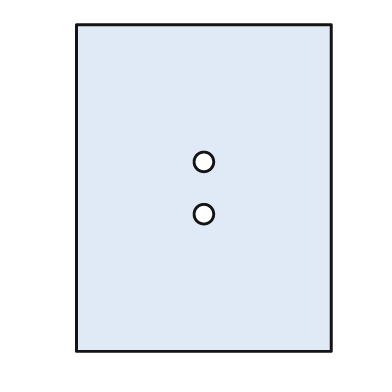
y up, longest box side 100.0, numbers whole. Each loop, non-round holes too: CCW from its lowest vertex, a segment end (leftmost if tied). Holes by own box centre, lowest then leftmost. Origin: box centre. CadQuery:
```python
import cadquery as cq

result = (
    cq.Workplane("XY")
    .moveTo(-39.0, -50.0)
    .lineTo(39.0, -50.0)
    .lineTo(39.0, 50.0)
    .lineTo(-39.0, 50.0)
    .close()
    .moveTo(0.0, -8.0)
    .circle(3.0)
    .moveTo(0.0, 8.0)
    .circle(3.0)
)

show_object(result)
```